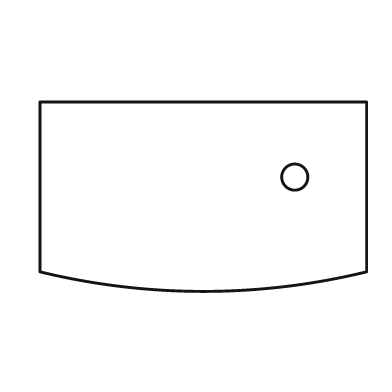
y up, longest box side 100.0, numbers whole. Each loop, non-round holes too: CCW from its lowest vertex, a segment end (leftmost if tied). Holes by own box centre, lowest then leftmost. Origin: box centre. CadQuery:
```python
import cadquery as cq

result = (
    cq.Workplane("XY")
    .moveTo(-50.0, -23.0)
    .threePointArc((0.0, -29.0), (50.0, -23.0))
    .lineTo(50.0, 29.0)
    .lineTo(-50.0, 29.0)
    .close()
    .moveTo(28.0, 6.0)
    .circle(4.0)
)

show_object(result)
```